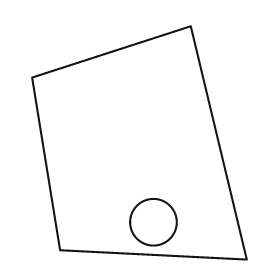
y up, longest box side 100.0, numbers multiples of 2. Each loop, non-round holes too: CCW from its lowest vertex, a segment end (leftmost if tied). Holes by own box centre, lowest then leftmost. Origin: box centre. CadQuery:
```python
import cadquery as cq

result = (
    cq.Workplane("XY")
    .moveTo(46.0, -50.0)
    .lineTo(22.0, 50.0)
    .lineTo(-46.0, 28.0)
    .lineTo(-34.0, -46.0)
    .close()
    .moveTo(6.0, -34.0)
    .circle(10.0)
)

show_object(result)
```